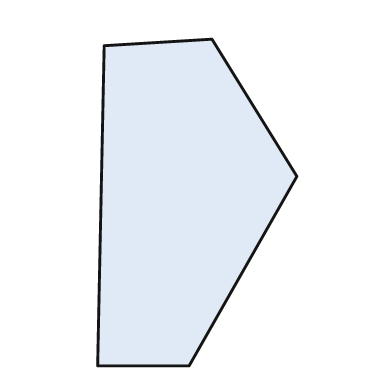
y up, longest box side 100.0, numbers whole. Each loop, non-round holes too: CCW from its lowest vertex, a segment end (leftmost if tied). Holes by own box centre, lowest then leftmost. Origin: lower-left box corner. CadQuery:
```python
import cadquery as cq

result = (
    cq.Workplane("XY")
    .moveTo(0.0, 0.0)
    .lineTo(28.0, 0.0)
    .lineTo(61.0, 58.0)
    .lineTo(35.0, 100.0)
    .lineTo(2.0, 98.0)
    .close()
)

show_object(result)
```